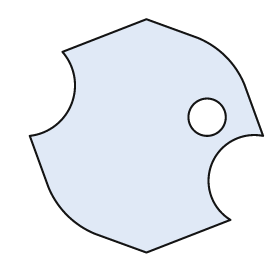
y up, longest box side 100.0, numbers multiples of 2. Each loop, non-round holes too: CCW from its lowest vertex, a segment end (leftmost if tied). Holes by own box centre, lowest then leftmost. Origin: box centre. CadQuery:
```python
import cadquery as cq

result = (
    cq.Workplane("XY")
    .moveTo(0.0, -50.0)
    .lineTo(36.0, -36.0)
    .threePointArc((28.0, -12.0), (50.0, 0.0))
    .lineTo(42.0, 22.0)
    .threePointArc((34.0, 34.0), (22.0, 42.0))
    .lineTo(0.0, 50.0)
    .lineTo(-36.0, 36.0)
    .threePointArc((-32.0, 14.0), (-50.0, 0.0))
    .lineTo(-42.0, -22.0)
    .threePointArc((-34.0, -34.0), (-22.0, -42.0))
    .close()
    .moveTo(26.0, 8.0)
    .circle(8.0)
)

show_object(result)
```